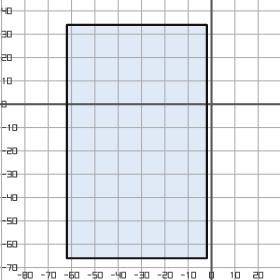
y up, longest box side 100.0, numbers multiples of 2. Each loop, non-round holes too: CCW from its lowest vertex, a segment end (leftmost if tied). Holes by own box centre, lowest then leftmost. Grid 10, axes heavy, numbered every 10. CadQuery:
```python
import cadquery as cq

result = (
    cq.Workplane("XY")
    .moveTo(-62.0, -66.0)
    .lineTo(-2.0, -66.0)
    .lineTo(-2.0, 34.0)
    .lineTo(-62.0, 34.0)
    .close()
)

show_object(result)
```